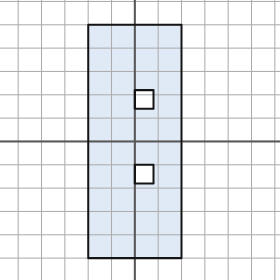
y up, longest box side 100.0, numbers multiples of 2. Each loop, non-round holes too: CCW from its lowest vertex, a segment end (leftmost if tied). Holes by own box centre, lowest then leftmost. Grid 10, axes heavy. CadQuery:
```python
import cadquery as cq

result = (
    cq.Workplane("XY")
    .moveTo(-20.0, -50.0)
    .lineTo(20.0, -50.0)
    .lineTo(20.0, 50.0)
    .lineTo(-20.0, 50.0)
    .close()
    .moveTo(0.0, -18.0)
    .lineTo(8.0, -18.0)
    .lineTo(8.0, -10.0)
    .lineTo(0.0, -10.0)
    .close()
    .moveTo(0.0, 14.0)
    .lineTo(8.0, 14.0)
    .lineTo(8.0, 22.0)
    .lineTo(0.0, 22.0)
    .close()
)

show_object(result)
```